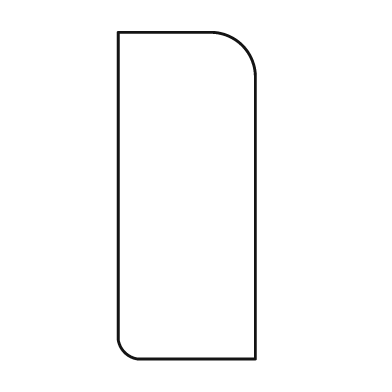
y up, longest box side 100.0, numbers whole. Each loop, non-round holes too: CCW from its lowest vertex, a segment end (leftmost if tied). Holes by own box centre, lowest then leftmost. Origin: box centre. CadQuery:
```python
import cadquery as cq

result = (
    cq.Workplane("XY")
    .moveTo(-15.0, -50.0)
    .lineTo(21.0, -50.0)
    .lineTo(21.0, 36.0)
    .threePointArc((17.0, 46.0), (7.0, 50.0))
    .lineTo(-21.0, 50.0)
    .lineTo(-21.0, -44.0)
    .threePointArc((-19.0, -48.0), (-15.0, -50.0))
    .close()
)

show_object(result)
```